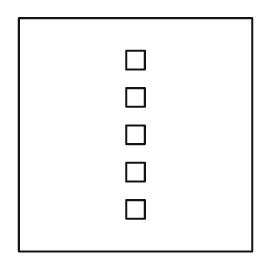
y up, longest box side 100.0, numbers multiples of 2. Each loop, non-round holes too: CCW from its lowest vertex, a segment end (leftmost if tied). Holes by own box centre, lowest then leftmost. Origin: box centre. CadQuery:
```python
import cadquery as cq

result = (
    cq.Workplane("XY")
    .moveTo(-50.0, -50.0)
    .lineTo(50.0, -50.0)
    .lineTo(50.0, 50.0)
    .lineTo(-50.0, 50.0)
    .close()
    .moveTo(-4.0, -36.0)
    .lineTo(4.0, -36.0)
    .lineTo(4.0, -28.0)
    .lineTo(-4.0, -28.0)
    .close()
    .moveTo(-4.0, -20.0)
    .lineTo(4.0, -20.0)
    .lineTo(4.0, -12.0)
    .lineTo(-4.0, -12.0)
    .close()
    .moveTo(-4.0, -4.0)
    .lineTo(4.0, -4.0)
    .lineTo(4.0, 4.0)
    .lineTo(-4.0, 4.0)
    .close()
    .moveTo(-4.0, 12.0)
    .lineTo(4.0, 12.0)
    .lineTo(4.0, 20.0)
    .lineTo(-4.0, 20.0)
    .close()
    .moveTo(-4.0, 28.0)
    .lineTo(4.0, 28.0)
    .lineTo(4.0, 36.0)
    .lineTo(-4.0, 36.0)
    .close()
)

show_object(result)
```